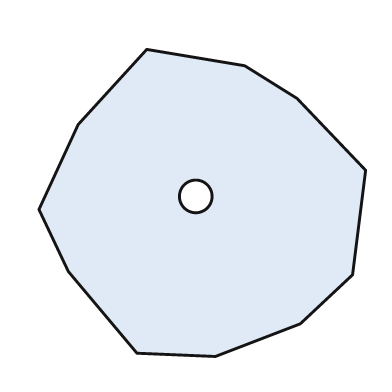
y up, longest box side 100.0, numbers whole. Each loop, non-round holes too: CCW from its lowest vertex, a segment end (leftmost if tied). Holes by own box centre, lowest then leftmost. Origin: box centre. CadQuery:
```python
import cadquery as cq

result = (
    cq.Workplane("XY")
    .moveTo(4.0, -47.0)
    .lineTo(30.0, -37.0)
    .lineTo(46.0, -22.0)
    .lineTo(50.0, 10.0)
    .lineTo(29.0, 32.0)
    .lineTo(13.0, 42.0)
    .lineTo(-17.0, 47.0)
    .lineTo(-38.0, 24.0)
    .lineTo(-50.0, -2.0)
    .lineTo(-41.0, -21.0)
    .lineTo(-20.0, -46.0)
    .close()
    .moveTo(-2.0, 2.0)
    .circle(5.0)
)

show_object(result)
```